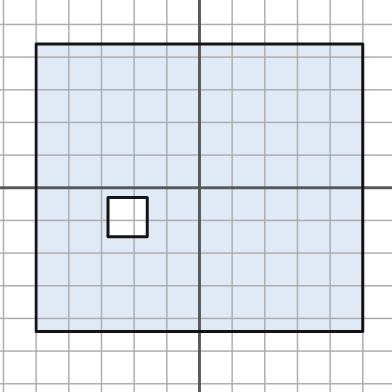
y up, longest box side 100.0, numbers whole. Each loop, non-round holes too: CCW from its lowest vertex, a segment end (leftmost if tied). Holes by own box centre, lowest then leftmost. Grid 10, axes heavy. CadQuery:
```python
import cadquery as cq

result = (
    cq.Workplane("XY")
    .moveTo(-50.0, -44.0)
    .lineTo(50.0, -44.0)
    .lineTo(50.0, 44.0)
    .lineTo(-50.0, 44.0)
    .close()
    .moveTo(-28.0, -15.0)
    .lineTo(-16.0, -15.0)
    .lineTo(-16.0, -3.0)
    .lineTo(-28.0, -3.0)
    .close()
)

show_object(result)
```